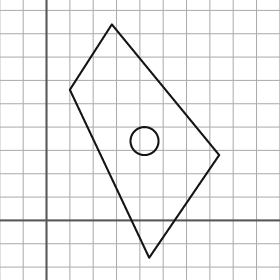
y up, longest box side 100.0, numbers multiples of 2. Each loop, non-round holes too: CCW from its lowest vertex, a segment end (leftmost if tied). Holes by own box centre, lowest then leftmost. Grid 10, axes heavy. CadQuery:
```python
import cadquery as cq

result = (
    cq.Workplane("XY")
    .moveTo(44.0, -16.0)
    .lineTo(74.0, 28.0)
    .lineTo(28.0, 84.0)
    .lineTo(10.0, 56.0)
    .close()
    .moveTo(42.0, 34.0)
    .circle(6.0)
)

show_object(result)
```